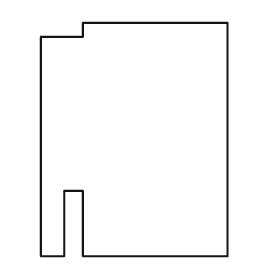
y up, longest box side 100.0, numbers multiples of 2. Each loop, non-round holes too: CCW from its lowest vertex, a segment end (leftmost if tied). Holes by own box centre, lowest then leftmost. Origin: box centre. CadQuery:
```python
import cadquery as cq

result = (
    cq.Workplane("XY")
    .moveTo(-40.0, -50.0)
    .lineTo(-30.0, -50.0)
    .lineTo(-30.0, -22.0)
    .lineTo(-22.0, -22.0)
    .lineTo(-22.0, -50.0)
    .lineTo(40.0, -50.0)
    .lineTo(40.0, 50.0)
    .lineTo(-22.0, 50.0)
    .lineTo(-22.0, 44.0)
    .lineTo(-40.0, 44.0)
    .close()
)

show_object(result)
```